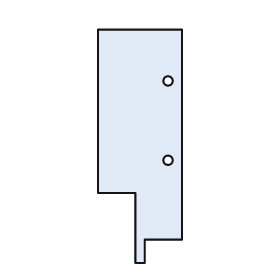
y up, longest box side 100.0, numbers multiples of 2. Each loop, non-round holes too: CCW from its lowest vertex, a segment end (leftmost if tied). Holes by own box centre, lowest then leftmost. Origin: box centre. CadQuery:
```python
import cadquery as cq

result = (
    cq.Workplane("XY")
    .moveTo(-2.0, -50.0)
    .lineTo(2.0, -50.0)
    .lineTo(2.0, -40.0)
    .lineTo(18.0, -40.0)
    .lineTo(18.0, 50.0)
    .lineTo(-18.0, 50.0)
    .lineTo(-18.0, -20.0)
    .lineTo(-2.0, -20.0)
    .close()
    .moveTo(12.0, -6.0)
    .circle(2.0)
    .moveTo(12.0, 28.0)
    .circle(2.0)
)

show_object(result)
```